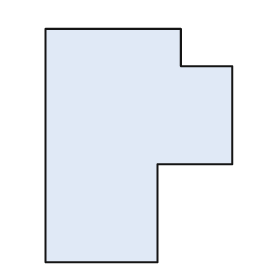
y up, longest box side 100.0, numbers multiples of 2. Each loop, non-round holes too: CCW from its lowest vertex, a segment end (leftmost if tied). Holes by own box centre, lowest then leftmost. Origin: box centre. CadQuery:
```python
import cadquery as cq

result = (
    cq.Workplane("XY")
    .moveTo(-40.0, -50.0)
    .lineTo(8.0, -50.0)
    .lineTo(8.0, -8.0)
    .lineTo(40.0, -8.0)
    .lineTo(40.0, 34.0)
    .lineTo(18.0, 34.0)
    .lineTo(18.0, 50.0)
    .lineTo(-40.0, 50.0)
    .close()
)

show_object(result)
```